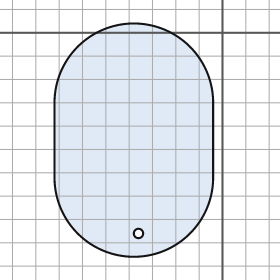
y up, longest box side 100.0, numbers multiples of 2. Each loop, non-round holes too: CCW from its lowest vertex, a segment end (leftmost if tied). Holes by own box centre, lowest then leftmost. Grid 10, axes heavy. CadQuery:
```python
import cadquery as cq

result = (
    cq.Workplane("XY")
    .moveTo(-72.0, -62.0)
    .threePointArc((-38.0, -96.0), (-4.0, -62.0))
    .lineTo(-4.0, -30.0)
    .threePointArc((-38.0, 4.0), (-72.0, -30.0))
    .close()
    .moveTo(-36.0, -86.0)
    .circle(2.0)
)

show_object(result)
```